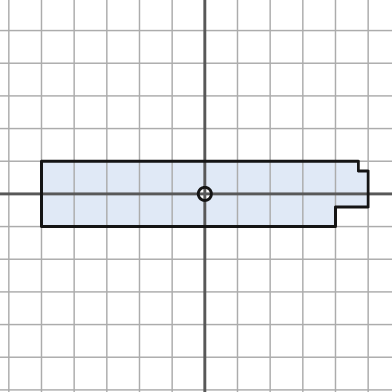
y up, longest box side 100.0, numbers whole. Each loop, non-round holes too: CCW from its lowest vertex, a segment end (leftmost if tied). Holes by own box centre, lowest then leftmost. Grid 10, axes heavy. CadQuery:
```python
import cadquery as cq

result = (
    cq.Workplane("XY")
    .moveTo(-50.0, -10.0)
    .lineTo(40.0, -10.0)
    .lineTo(40.0, -4.0)
    .lineTo(50.0, -4.0)
    .lineTo(50.0, 7.0)
    .lineTo(47.0, 7.0)
    .lineTo(47.0, 10.0)
    .lineTo(-50.0, 10.0)
    .close()
    .moveTo(0.0, 0.0)
    .circle(2.0)
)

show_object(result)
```